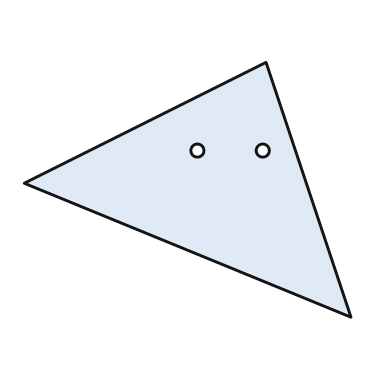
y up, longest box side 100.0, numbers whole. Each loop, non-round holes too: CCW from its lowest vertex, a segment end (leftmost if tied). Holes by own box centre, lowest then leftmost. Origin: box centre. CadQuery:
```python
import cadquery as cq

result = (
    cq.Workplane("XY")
    .moveTo(50.0, -39.0)
    .lineTo(24.0, 39.0)
    .lineTo(-50.0, 2.0)
    .close()
    .moveTo(3.0, 12.0)
    .circle(2.0)
    .moveTo(23.0, 12.0)
    .circle(2.0)
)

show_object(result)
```